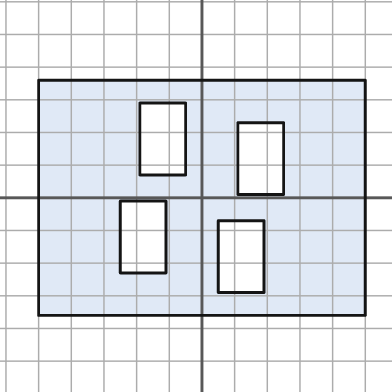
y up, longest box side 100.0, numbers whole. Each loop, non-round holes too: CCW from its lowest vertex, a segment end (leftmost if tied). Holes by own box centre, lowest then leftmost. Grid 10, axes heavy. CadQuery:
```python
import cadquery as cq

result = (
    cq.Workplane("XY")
    .moveTo(-50.0, -36.0)
    .lineTo(50.0, -36.0)
    .lineTo(50.0, 36.0)
    .lineTo(-50.0, 36.0)
    .close()
    .moveTo(5.0, -29.0)
    .lineTo(19.0, -29.0)
    .lineTo(19.0, -7.0)
    .lineTo(5.0, -7.0)
    .close()
    .moveTo(-25.0, -23.0)
    .lineTo(-11.0, -23.0)
    .lineTo(-11.0, -1.0)
    .lineTo(-25.0, -1.0)
    .close()
    .moveTo(11.0, 1.0)
    .lineTo(25.0, 1.0)
    .lineTo(25.0, 23.0)
    .lineTo(11.0, 23.0)
    .close()
    .moveTo(-19.0, 7.0)
    .lineTo(-5.0, 7.0)
    .lineTo(-5.0, 29.0)
    .lineTo(-19.0, 29.0)
    .close()
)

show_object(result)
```